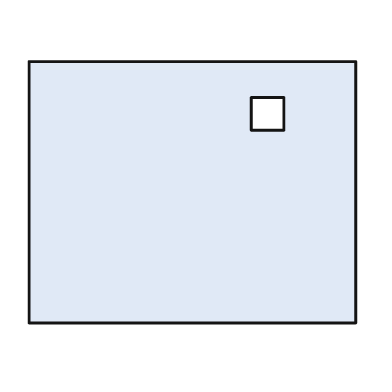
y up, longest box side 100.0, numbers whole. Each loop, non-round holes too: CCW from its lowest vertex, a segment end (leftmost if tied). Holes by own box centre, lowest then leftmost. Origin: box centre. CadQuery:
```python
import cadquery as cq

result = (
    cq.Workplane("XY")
    .moveTo(-50.0, -40.0)
    .lineTo(50.0, -40.0)
    .lineTo(50.0, 40.0)
    .lineTo(-50.0, 40.0)
    .close()
    .moveTo(18.0, 19.0)
    .lineTo(28.0, 19.0)
    .lineTo(28.0, 29.0)
    .lineTo(18.0, 29.0)
    .close()
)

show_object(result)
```